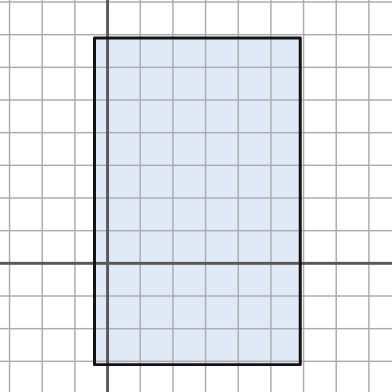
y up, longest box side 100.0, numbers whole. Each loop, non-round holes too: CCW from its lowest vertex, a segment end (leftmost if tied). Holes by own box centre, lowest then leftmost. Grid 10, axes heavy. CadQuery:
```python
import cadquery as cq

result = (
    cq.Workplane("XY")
    .moveTo(-4.0, -31.0)
    .lineTo(59.0, -31.0)
    .lineTo(59.0, 69.0)
    .lineTo(-4.0, 69.0)
    .close()
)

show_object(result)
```